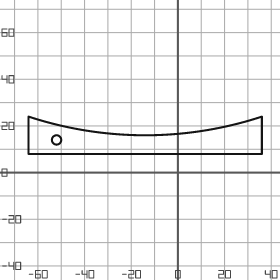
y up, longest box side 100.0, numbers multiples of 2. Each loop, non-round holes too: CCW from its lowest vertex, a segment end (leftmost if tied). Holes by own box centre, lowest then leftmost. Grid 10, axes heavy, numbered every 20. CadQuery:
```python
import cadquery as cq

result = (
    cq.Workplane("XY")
    .moveTo(-64.0, 8.0)
    .lineTo(36.0, 8.0)
    .lineTo(36.0, 24.0)
    .threePointArc((-14.0, 16.0), (-64.0, 24.0))
    .close()
    .moveTo(-52.0, 14.0)
    .circle(2.0)
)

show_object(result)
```